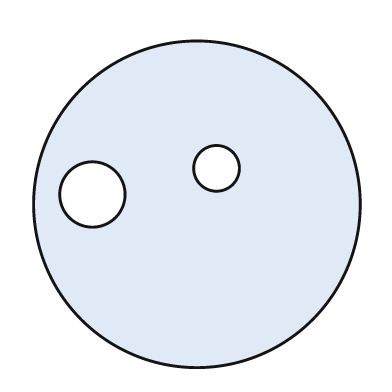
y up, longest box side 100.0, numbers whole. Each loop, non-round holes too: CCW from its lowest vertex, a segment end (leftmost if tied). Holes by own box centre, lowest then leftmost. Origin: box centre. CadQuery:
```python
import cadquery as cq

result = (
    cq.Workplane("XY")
    .moveTo(0.0, 0.0)
    .circle(50.0)
    .moveTo(-32.0, 3.0)
    .circle(10.0)
    .moveTo(6.0, 11.0)
    .circle(7.0)
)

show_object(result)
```